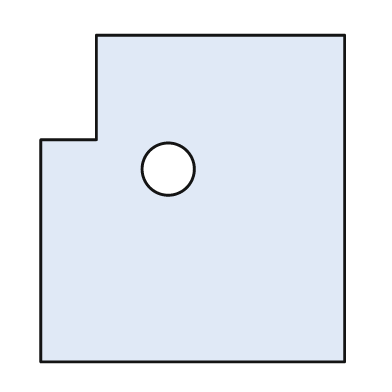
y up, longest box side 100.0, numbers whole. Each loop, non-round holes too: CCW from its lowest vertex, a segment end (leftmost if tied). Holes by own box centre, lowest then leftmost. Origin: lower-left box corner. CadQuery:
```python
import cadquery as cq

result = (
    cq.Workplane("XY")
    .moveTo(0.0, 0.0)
    .lineTo(93.0, 0.0)
    .lineTo(93.0, 100.0)
    .lineTo(17.0, 100.0)
    .lineTo(17.0, 68.0)
    .lineTo(0.0, 68.0)
    .close()
    .moveTo(39.0, 59.0)
    .circle(8.0)
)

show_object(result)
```